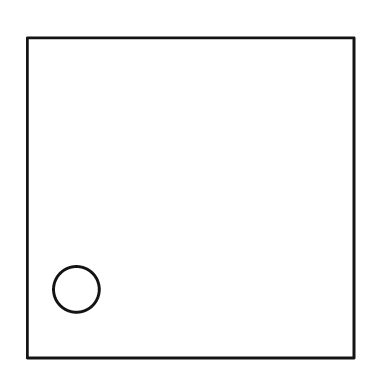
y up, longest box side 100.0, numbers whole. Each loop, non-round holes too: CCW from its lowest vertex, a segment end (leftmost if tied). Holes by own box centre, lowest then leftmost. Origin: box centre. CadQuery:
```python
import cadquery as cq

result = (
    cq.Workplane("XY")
    .moveTo(-50.0, -49.0)
    .lineTo(50.0, -49.0)
    .lineTo(50.0, 49.0)
    .lineTo(-50.0, 49.0)
    .close()
    .moveTo(-35.0, -28.0)
    .circle(7.0)
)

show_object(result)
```